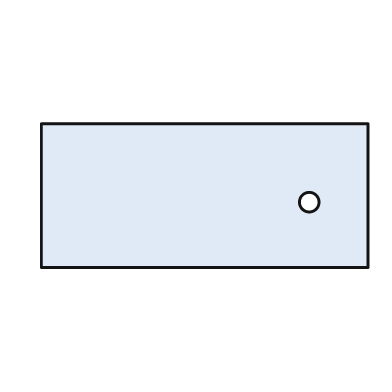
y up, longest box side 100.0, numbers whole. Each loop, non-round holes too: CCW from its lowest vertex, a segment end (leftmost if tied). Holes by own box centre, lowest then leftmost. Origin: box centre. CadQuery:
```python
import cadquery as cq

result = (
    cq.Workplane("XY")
    .moveTo(-50.0, -22.0)
    .lineTo(50.0, -22.0)
    .lineTo(50.0, 22.0)
    .lineTo(-50.0, 22.0)
    .close()
    .moveTo(32.0, -2.0)
    .circle(3.0)
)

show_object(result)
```